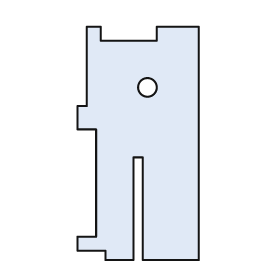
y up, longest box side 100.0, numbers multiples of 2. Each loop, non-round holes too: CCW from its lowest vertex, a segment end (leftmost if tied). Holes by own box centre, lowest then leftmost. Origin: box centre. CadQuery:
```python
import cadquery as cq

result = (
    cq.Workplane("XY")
    .moveTo(-14.0, -50.0)
    .lineTo(-2.0, -50.0)
    .lineTo(-2.0, -6.0)
    .lineTo(2.0, -6.0)
    .lineTo(2.0, -50.0)
    .lineTo(26.0, -50.0)
    .lineTo(26.0, 50.0)
    .lineTo(8.0, 50.0)
    .lineTo(8.0, 44.0)
    .lineTo(-16.0, 44.0)
    .lineTo(-16.0, 50.0)
    .lineTo(-22.0, 50.0)
    .lineTo(-22.0, 16.0)
    .lineTo(-26.0, 16.0)
    .lineTo(-26.0, 6.0)
    .lineTo(-18.0, 6.0)
    .lineTo(-18.0, -40.0)
    .lineTo(-26.0, -40.0)
    .lineTo(-26.0, -46.0)
    .lineTo(-14.0, -46.0)
    .close()
    .moveTo(4.0, 24.0)
    .circle(4.0)
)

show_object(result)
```